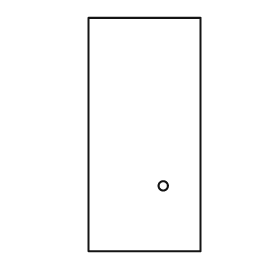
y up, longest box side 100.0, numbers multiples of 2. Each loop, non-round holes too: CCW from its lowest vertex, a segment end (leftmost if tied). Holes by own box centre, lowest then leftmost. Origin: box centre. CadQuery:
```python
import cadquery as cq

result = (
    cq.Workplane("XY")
    .moveTo(-24.0, -50.0)
    .lineTo(24.0, -50.0)
    .lineTo(24.0, 50.0)
    .lineTo(-24.0, 50.0)
    .close()
    .moveTo(8.0, -22.0)
    .circle(2.0)
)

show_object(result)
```